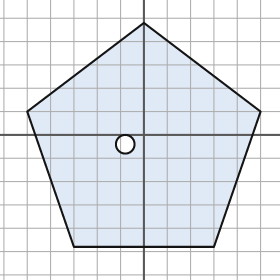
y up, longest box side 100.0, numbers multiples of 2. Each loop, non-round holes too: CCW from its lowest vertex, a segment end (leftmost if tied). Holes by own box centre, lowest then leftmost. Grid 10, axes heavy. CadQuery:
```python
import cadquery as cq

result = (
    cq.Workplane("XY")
    .moveTo(-30.0, -48.0)
    .lineTo(30.0, -48.0)
    .lineTo(50.0, 10.0)
    .lineTo(0.0, 48.0)
    .lineTo(-50.0, 10.0)
    .close()
    .moveTo(-8.0, -4.0)
    .circle(4.0)
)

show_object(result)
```